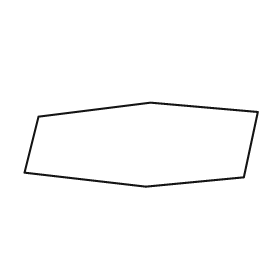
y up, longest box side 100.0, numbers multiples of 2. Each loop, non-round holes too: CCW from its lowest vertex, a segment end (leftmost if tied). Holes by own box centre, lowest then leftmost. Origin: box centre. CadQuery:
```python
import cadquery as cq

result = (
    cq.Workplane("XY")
    .moveTo(2.0, -18.0)
    .lineTo(44.0, -14.0)
    .lineTo(50.0, 14.0)
    .lineTo(4.0, 18.0)
    .lineTo(-44.0, 12.0)
    .lineTo(-50.0, -12.0)
    .close()
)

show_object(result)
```